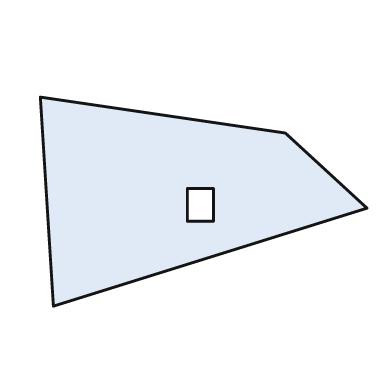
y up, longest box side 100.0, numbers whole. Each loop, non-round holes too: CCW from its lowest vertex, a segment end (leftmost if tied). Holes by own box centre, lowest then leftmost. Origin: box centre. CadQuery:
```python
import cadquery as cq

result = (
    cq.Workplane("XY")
    .moveTo(-46.0, -32.0)
    .lineTo(50.0, -2.0)
    .lineTo(25.0, 21.0)
    .lineTo(-50.0, 32.0)
    .close()
    .moveTo(-5.0, -6.0)
    .lineTo(3.0, -6.0)
    .lineTo(3.0, 4.0)
    .lineTo(-5.0, 4.0)
    .close()
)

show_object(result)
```